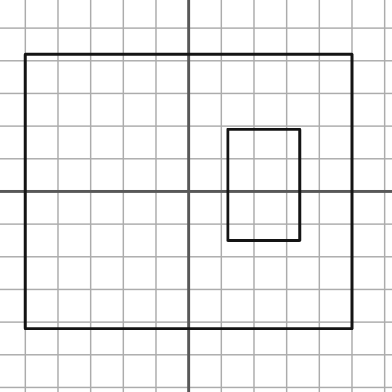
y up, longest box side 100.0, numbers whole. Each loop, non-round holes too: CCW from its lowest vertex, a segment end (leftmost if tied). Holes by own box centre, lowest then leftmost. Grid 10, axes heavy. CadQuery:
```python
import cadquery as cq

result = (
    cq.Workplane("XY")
    .moveTo(-50.0, -42.0)
    .lineTo(50.0, -42.0)
    .lineTo(50.0, 42.0)
    .lineTo(-50.0, 42.0)
    .close()
    .moveTo(12.0, -15.0)
    .lineTo(34.0, -15.0)
    .lineTo(34.0, 19.0)
    .lineTo(12.0, 19.0)
    .close()
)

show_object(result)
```